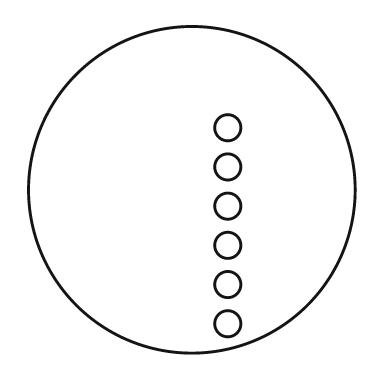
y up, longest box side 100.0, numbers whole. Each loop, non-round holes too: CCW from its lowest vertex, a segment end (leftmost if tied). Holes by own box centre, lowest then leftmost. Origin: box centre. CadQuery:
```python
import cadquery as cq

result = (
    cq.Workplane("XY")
    .moveTo(0.0, 0.0)
    .circle(50.0)
    .moveTo(11.0, -41.0)
    .circle(4.0)
    .moveTo(11.0, -29.0)
    .circle(4.0)
    .moveTo(11.0, -17.0)
    .circle(4.0)
    .moveTo(11.0, -5.0)
    .circle(4.0)
    .moveTo(11.0, 7.0)
    .circle(4.0)
    .moveTo(11.0, 19.0)
    .circle(4.0)
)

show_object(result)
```